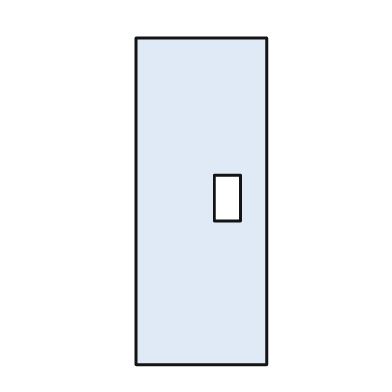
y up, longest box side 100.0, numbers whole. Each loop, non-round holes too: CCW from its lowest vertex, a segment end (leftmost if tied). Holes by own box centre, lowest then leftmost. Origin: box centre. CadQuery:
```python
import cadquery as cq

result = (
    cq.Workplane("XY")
    .moveTo(-20.0, -50.0)
    .lineTo(20.0, -50.0)
    .lineTo(20.0, 50.0)
    .lineTo(-20.0, 50.0)
    .close()
    .moveTo(4.0, -6.0)
    .lineTo(12.0, -6.0)
    .lineTo(12.0, 8.0)
    .lineTo(4.0, 8.0)
    .close()
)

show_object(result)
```